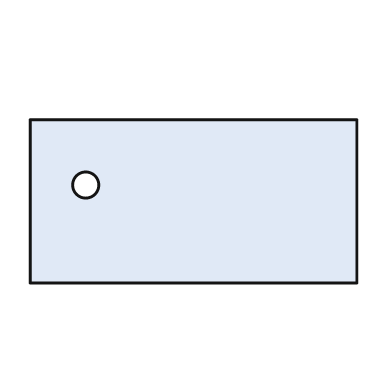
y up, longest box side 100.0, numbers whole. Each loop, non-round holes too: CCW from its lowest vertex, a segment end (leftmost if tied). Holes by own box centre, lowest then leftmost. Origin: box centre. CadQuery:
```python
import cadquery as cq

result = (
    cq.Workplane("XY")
    .moveTo(-50.0, -25.0)
    .lineTo(50.0, -25.0)
    .lineTo(50.0, 25.0)
    .lineTo(-50.0, 25.0)
    .close()
    .moveTo(-33.0, 5.0)
    .circle(4.0)
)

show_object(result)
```